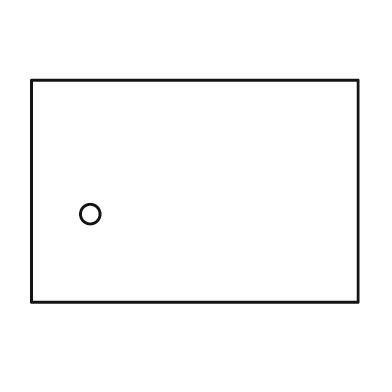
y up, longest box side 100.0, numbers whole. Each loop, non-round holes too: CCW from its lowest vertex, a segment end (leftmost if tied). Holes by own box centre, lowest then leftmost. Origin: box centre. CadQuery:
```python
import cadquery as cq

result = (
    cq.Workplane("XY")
    .moveTo(-50.0, -34.0)
    .lineTo(50.0, -34.0)
    .lineTo(50.0, 34.0)
    .lineTo(-50.0, 34.0)
    .close()
    .moveTo(-32.0, -7.0)
    .circle(3.0)
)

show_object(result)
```